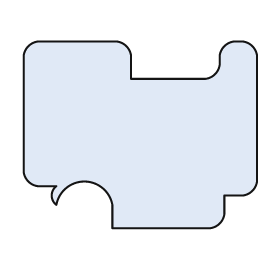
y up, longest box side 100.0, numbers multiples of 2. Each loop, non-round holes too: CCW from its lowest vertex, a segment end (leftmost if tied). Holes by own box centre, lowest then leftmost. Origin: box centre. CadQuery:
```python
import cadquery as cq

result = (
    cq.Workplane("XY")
    .moveTo(-12.0, -40.0)
    .lineTo(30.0, -40.0)
    .threePointArc((34.0, -38.0), (36.0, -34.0))
    .lineTo(36.0, -26.0)
    .lineTo(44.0, -26.0)
    .threePointArc((48.0, -24.0), (50.0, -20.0))
    .lineTo(50.0, 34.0)
    .threePointArc((48.0, 38.0), (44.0, 40.0))
    .lineTo(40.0, 40.0)
    .threePointArc((36.0, 38.0), (34.0, 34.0))
    .lineTo(34.0, 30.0)
    .threePointArc((32.0, 26.0), (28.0, 24.0))
    .lineTo(-4.0, 24.0)
    .lineTo(-4.0, 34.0)
    .threePointArc((-6.0, 38.0), (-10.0, 40.0))
    .lineTo(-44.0, 40.0)
    .threePointArc((-48.0, 38.0), (-50.0, 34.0))
    .lineTo(-50.0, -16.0)
    .threePointArc((-48.0, -20.0), (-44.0, -22.0))
    .lineTo(-36.0, -22.0)
    .threePointArc((-38.0, -26.0), (-36.0, -30.0))
    .threePointArc((-24.0, -20.0), (-12.0, -30.0))
    .close()
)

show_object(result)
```